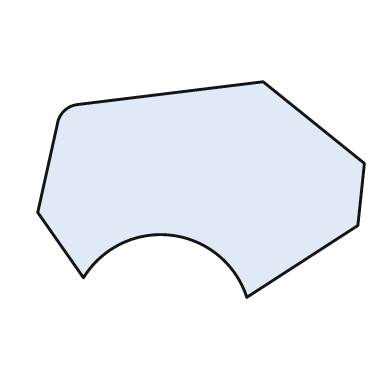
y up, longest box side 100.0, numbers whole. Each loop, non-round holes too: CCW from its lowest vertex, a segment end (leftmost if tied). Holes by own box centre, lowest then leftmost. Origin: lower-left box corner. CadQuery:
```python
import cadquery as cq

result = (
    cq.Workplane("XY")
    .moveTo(64.0, 0.0)
    .lineTo(98.0, 22.0)
    .lineTo(100.0, 41.0)
    .lineTo(69.0, 66.0)
    .lineTo(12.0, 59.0)
    .threePointArc((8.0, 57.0), (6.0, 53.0))
    .lineTo(0.0, 26.0)
    .lineTo(14.0, 6.0)
    .threePointArc((41.0, 19.0), (64.0, 0.0))
    .close()
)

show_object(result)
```